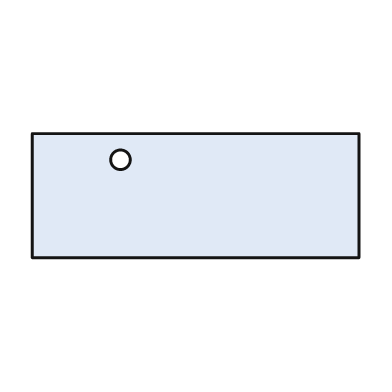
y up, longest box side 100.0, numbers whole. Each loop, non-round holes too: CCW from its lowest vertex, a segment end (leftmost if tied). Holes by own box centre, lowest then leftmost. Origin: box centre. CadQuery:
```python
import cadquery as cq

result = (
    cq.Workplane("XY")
    .moveTo(-50.0, -19.0)
    .lineTo(50.0, -19.0)
    .lineTo(50.0, 19.0)
    .lineTo(-50.0, 19.0)
    .close()
    .moveTo(-23.0, 11.0)
    .circle(3.0)
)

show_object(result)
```